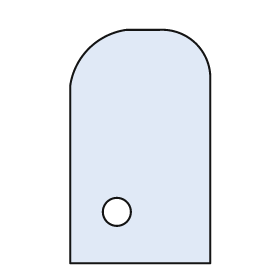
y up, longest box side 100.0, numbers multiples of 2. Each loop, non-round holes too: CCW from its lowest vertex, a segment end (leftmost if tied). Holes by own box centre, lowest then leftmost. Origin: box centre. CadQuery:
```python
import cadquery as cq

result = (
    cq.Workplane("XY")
    .moveTo(-30.0, -50.0)
    .lineTo(30.0, -50.0)
    .lineTo(30.0, 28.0)
    .threePointArc((24.0, 44.0), (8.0, 50.0))
    .lineTo(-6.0, 50.0)
    .threePointArc((-22.0, 42.0), (-30.0, 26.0))
    .close()
    .moveTo(-10.0, -28.0)
    .circle(6.0)
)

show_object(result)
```